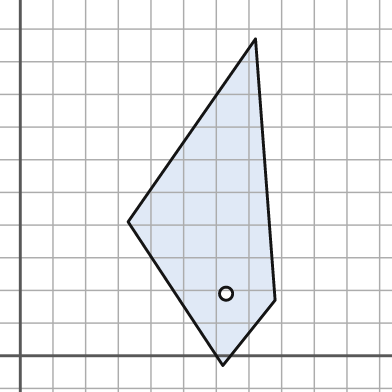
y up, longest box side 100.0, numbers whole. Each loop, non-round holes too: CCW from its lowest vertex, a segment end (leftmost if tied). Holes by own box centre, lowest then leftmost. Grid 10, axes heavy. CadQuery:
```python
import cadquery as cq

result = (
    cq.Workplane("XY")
    .moveTo(62.0, -3.0)
    .lineTo(78.0, 17.0)
    .lineTo(72.0, 97.0)
    .lineTo(33.0, 41.0)
    .close()
    .moveTo(63.0, 19.0)
    .circle(2.0)
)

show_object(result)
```